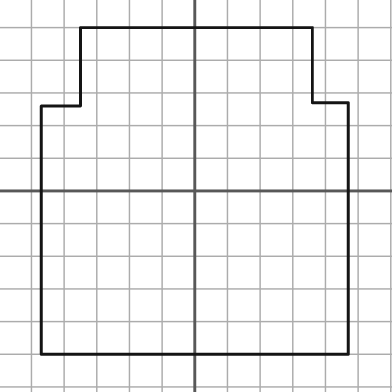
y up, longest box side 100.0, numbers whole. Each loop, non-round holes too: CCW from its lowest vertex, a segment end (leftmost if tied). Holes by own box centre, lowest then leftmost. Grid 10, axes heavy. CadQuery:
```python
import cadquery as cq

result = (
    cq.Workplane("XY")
    .moveTo(-47.0, -50.0)
    .lineTo(47.0, -50.0)
    .lineTo(47.0, 27.0)
    .lineTo(36.0, 27.0)
    .lineTo(36.0, 50.0)
    .lineTo(-35.0, 50.0)
    .lineTo(-35.0, 26.0)
    .lineTo(-47.0, 26.0)
    .close()
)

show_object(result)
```